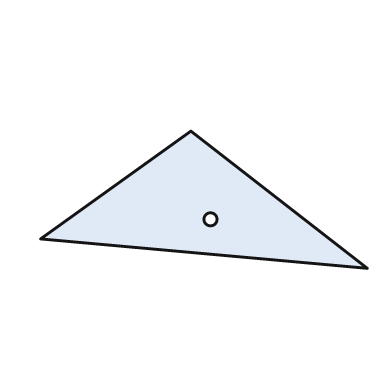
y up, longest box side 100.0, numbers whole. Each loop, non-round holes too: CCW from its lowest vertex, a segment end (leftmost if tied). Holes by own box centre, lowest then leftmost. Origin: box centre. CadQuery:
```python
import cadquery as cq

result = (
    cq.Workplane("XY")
    .moveTo(50.0, -21.0)
    .lineTo(-4.0, 21.0)
    .lineTo(-50.0, -12.0)
    .close()
    .moveTo(2.0, -6.0)
    .circle(2.0)
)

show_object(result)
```